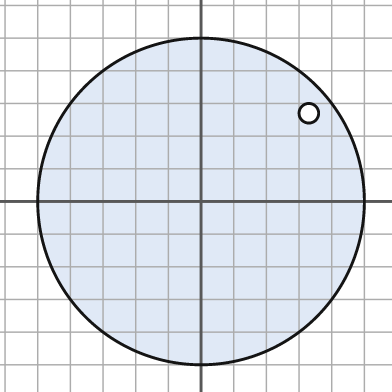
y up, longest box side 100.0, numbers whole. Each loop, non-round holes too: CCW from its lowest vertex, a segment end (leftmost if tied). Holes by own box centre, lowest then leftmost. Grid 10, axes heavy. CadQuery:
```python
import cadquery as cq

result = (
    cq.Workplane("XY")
    .moveTo(0.0, 0.0)
    .circle(50.0)
    .moveTo(33.0, 27.0)
    .circle(3.0)
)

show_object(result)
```